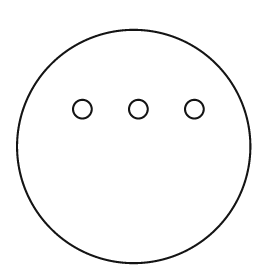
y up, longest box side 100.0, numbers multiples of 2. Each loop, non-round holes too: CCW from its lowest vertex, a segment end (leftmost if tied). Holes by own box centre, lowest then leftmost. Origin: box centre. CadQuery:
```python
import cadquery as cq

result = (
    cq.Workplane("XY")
    .moveTo(0.0, 0.0)
    .circle(50.0)
    .moveTo(-22.0, 16.0)
    .circle(4.0)
    .moveTo(2.0, 16.0)
    .circle(4.0)
    .moveTo(26.0, 16.0)
    .circle(4.0)
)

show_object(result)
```